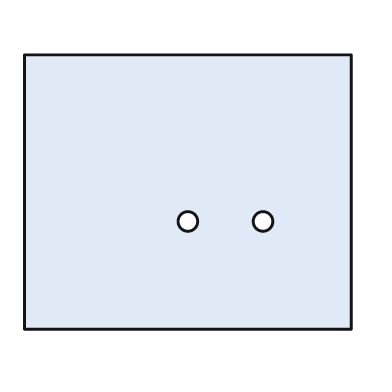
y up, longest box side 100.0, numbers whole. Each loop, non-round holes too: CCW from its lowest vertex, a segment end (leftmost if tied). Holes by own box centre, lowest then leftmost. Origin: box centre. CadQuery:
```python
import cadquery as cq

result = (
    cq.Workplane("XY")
    .moveTo(-50.0, -42.0)
    .lineTo(50.0, -42.0)
    .lineTo(50.0, 42.0)
    .lineTo(-50.0, 42.0)
    .close()
    .moveTo(0.0, -9.0)
    .circle(3.0)
    .moveTo(23.0, -9.0)
    .circle(3.0)
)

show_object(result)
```